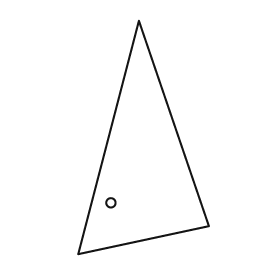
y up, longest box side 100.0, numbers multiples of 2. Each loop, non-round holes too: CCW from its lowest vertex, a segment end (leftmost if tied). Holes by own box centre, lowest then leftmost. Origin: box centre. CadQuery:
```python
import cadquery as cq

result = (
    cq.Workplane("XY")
    .moveTo(-28.0, -50.0)
    .lineTo(28.0, -38.0)
    .lineTo(-2.0, 50.0)
    .close()
    .moveTo(-14.0, -28.0)
    .circle(2.0)
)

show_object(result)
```